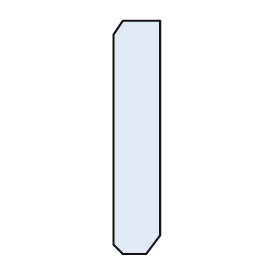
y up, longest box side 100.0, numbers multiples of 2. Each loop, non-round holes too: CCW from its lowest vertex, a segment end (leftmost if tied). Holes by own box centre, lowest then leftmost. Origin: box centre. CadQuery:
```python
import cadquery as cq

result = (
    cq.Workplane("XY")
    .moveTo(-6.0, -50.0)
    .lineTo(4.0, -50.0)
    .lineTo(10.0, -42.0)
    .lineTo(10.0, 50.0)
    .lineTo(-6.0, 50.0)
    .lineTo(-10.0, 44.0)
    .lineTo(-10.0, -46.0)
    .close()
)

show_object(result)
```